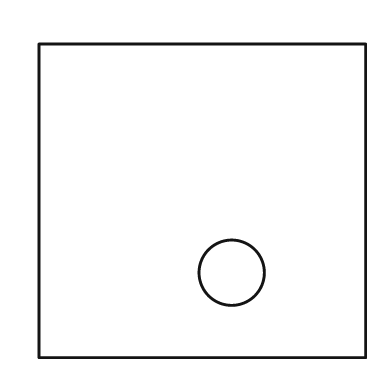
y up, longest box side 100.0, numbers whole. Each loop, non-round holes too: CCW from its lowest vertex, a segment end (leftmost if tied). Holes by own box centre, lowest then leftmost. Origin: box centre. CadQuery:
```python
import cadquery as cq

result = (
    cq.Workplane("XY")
    .moveTo(-50.0, -48.0)
    .lineTo(50.0, -48.0)
    .lineTo(50.0, 48.0)
    .lineTo(-50.0, 48.0)
    .close()
    .moveTo(9.0, -22.0)
    .circle(10.0)
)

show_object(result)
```